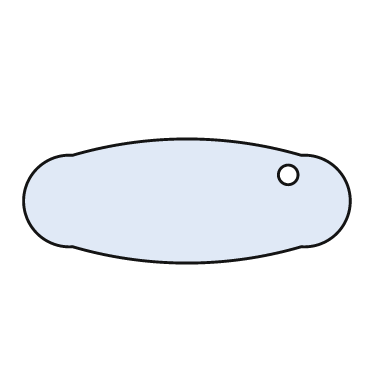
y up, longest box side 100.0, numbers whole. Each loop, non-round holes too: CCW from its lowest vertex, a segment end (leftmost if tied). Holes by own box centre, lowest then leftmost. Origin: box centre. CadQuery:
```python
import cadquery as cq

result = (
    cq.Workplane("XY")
    .moveTo(-35.0, -14.0)
    .threePointArc((0.0, -19.0), (35.0, -14.0))
    .threePointArc((50.0, 0.0), (35.0, 14.0))
    .threePointArc((0.0, 19.0), (-35.0, 14.0))
    .threePointArc((-50.0, 0.0), (-35.0, -14.0))
    .close()
    .moveTo(31.0, 8.0)
    .circle(3.0)
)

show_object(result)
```